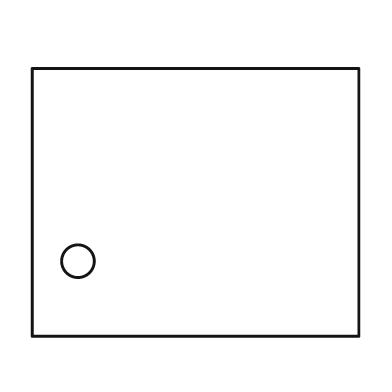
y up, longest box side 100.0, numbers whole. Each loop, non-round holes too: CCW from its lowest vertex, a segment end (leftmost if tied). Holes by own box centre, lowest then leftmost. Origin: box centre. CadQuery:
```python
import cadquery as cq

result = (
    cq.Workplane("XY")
    .moveTo(-50.0, -41.0)
    .lineTo(50.0, -41.0)
    .lineTo(50.0, 41.0)
    .lineTo(-50.0, 41.0)
    .close()
    .moveTo(-36.0, -18.0)
    .circle(5.0)
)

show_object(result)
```